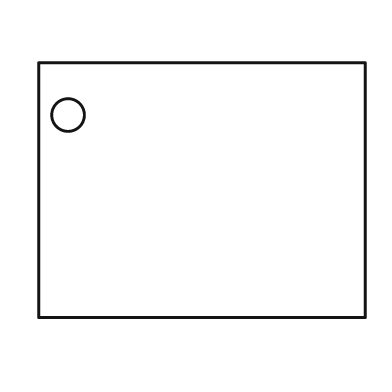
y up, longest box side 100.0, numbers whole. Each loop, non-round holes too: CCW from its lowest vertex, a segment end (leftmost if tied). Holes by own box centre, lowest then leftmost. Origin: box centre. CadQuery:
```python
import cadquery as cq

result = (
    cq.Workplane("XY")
    .moveTo(-50.0, -39.0)
    .lineTo(50.0, -39.0)
    .lineTo(50.0, 39.0)
    .lineTo(-50.0, 39.0)
    .close()
    .moveTo(-41.0, 23.0)
    .circle(5.0)
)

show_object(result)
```